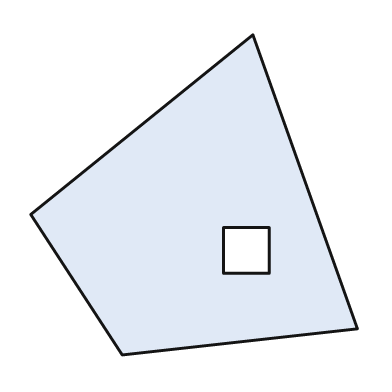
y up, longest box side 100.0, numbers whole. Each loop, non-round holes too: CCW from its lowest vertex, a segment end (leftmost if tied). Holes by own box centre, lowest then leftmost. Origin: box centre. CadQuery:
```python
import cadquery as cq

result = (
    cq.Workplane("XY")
    .moveTo(-22.0, -49.0)
    .lineTo(50.0, -41.0)
    .lineTo(18.0, 49.0)
    .lineTo(-50.0, -6.0)
    .close()
    .moveTo(9.0, -24.0)
    .lineTo(23.0, -24.0)
    .lineTo(23.0, -10.0)
    .lineTo(9.0, -10.0)
    .close()
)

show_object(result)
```